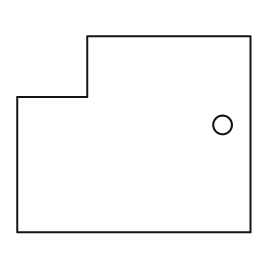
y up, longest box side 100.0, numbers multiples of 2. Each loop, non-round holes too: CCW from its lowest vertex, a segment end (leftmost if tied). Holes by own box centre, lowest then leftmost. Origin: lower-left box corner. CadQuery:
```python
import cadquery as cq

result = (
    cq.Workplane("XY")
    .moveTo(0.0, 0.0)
    .lineTo(100.0, 0.0)
    .lineTo(100.0, 84.0)
    .lineTo(30.0, 84.0)
    .lineTo(30.0, 58.0)
    .lineTo(0.0, 58.0)
    .close()
    .moveTo(88.0, 46.0)
    .circle(4.0)
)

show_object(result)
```